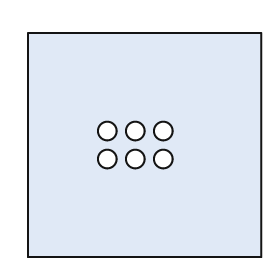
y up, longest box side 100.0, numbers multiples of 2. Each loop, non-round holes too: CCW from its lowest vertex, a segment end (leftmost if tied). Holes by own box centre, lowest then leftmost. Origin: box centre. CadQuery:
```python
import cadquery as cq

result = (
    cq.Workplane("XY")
    .moveTo(-50.0, -48.0)
    .lineTo(50.0, -48.0)
    .lineTo(50.0, 48.0)
    .lineTo(-50.0, 48.0)
    .close()
    .moveTo(-16.0, -6.0)
    .circle(4.0)
    .moveTo(-4.0, -6.0)
    .circle(4.0)
    .moveTo(8.0, -6.0)
    .circle(4.0)
    .moveTo(-16.0, 6.0)
    .circle(4.0)
    .moveTo(-4.0, 6.0)
    .circle(4.0)
    .moveTo(8.0, 6.0)
    .circle(4.0)
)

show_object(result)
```